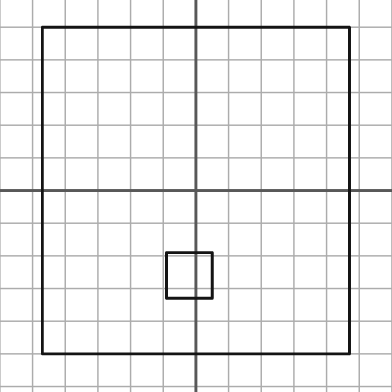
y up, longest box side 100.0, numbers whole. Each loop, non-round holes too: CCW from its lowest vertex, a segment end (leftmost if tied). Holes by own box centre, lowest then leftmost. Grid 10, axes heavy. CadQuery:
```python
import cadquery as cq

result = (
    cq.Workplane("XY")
    .moveTo(-47.0, -50.0)
    .lineTo(47.0, -50.0)
    .lineTo(47.0, 50.0)
    .lineTo(-47.0, 50.0)
    .close()
    .moveTo(-9.0, -33.0)
    .lineTo(5.0, -33.0)
    .lineTo(5.0, -19.0)
    .lineTo(-9.0, -19.0)
    .close()
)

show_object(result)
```